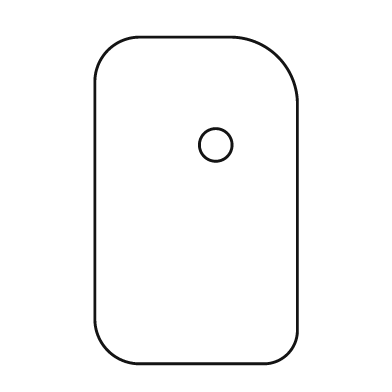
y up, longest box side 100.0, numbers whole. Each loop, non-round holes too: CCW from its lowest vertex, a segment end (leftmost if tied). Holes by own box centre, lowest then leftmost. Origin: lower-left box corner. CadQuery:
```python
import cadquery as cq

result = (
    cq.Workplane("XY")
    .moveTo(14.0, 0.0)
    .lineTo(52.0, 0.0)
    .threePointArc((59.0, 3.0), (62.0, 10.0))
    .lineTo(62.0, 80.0)
    .threePointArc((56.0, 94.0), (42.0, 100.0))
    .lineTo(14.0, 100.0)
    .threePointArc((4.0, 96.0), (0.0, 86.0))
    .lineTo(0.0, 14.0)
    .threePointArc((4.0, 4.0), (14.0, 0.0))
    .close()
    .moveTo(37.0, 67.0)
    .circle(5.0)
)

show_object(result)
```